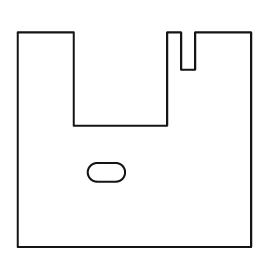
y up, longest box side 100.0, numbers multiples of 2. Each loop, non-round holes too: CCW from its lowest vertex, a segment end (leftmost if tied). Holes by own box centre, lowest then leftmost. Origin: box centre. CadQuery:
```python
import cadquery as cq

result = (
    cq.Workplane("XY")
    .moveTo(-50.0, -46.0)
    .lineTo(50.0, -46.0)
    .lineTo(50.0, 46.0)
    .lineTo(26.0, 46.0)
    .lineTo(26.0, 30.0)
    .lineTo(20.0, 30.0)
    .lineTo(20.0, 46.0)
    .lineTo(14.0, 46.0)
    .lineTo(14.0, 6.0)
    .lineTo(-26.0, 6.0)
    .lineTo(-26.0, 46.0)
    .lineTo(-50.0, 46.0)
    .close()
    .moveTo(-16.0, -18.0)
    .lineTo(-8.0, -18.0)
    .threePointArc((-4.0, -14.0), (-8.0, -10.0))
    .lineTo(-16.0, -10.0)
    .threePointArc((-20.0, -14.0), (-16.0, -18.0))
    .close()
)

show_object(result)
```